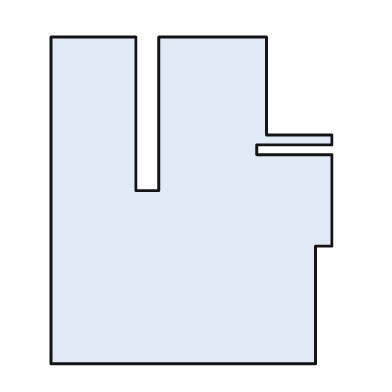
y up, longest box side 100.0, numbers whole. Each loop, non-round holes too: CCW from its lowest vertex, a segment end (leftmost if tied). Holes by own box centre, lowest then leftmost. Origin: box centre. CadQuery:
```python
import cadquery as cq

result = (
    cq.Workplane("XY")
    .moveTo(-43.0, -50.0)
    .lineTo(38.0, -50.0)
    .lineTo(38.0, -14.0)
    .lineTo(43.0, -14.0)
    .lineTo(43.0, 14.0)
    .lineTo(20.0, 14.0)
    .lineTo(20.0, 17.0)
    .lineTo(43.0, 17.0)
    .lineTo(43.0, 20.0)
    .lineTo(23.0, 20.0)
    .lineTo(23.0, 50.0)
    .lineTo(-10.0, 50.0)
    .lineTo(-10.0, 3.0)
    .lineTo(-17.0, 3.0)
    .lineTo(-17.0, 50.0)
    .lineTo(-43.0, 50.0)
    .close()
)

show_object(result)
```